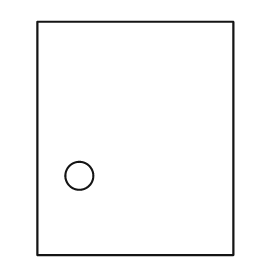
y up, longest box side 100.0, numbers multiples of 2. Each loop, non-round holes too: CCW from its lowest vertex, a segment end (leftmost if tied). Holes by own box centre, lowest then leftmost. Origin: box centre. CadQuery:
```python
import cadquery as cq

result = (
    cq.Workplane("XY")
    .moveTo(-42.0, -50.0)
    .lineTo(42.0, -50.0)
    .lineTo(42.0, 50.0)
    .lineTo(-42.0, 50.0)
    .close()
    .moveTo(-24.0, -16.0)
    .circle(6.0)
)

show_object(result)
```